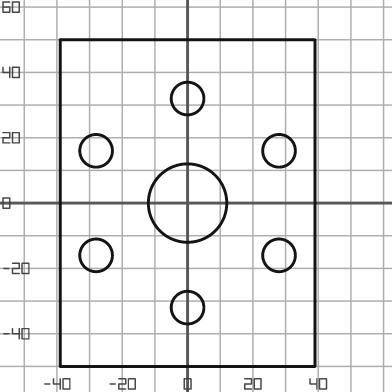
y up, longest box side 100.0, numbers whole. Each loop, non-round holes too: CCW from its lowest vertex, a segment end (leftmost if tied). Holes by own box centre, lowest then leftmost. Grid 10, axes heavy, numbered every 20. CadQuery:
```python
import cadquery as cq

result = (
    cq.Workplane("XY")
    .moveTo(-39.0, -50.0)
    .lineTo(39.0, -50.0)
    .lineTo(39.0, 50.0)
    .lineTo(-39.0, 50.0)
    .close()
    .moveTo(0.0, -32.0)
    .circle(5.0)
    .moveTo(-28.0, -16.0)
    .circle(5.0)
    .moveTo(28.0, -16.0)
    .circle(5.0)
    .moveTo(0.0, 0.0)
    .circle(12.0)
    .moveTo(-28.0, 16.0)
    .circle(5.0)
    .moveTo(28.0, 16.0)
    .circle(5.0)
    .moveTo(0.0, 32.0)
    .circle(5.0)
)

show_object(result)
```